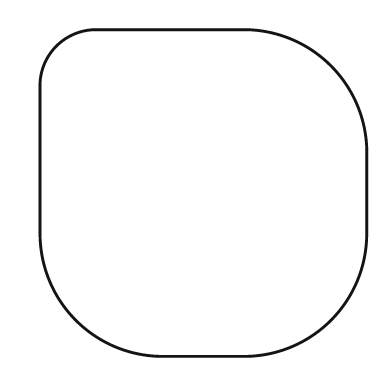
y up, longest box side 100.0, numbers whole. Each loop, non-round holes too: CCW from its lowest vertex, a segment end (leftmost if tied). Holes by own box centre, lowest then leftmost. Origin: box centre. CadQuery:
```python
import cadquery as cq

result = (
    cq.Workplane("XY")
    .moveTo(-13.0, -50.0)
    .lineTo(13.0, -50.0)
    .threePointArc((39.0, -39.0), (50.0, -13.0))
    .lineTo(50.0, 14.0)
    .threePointArc((39.0, 39.0), (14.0, 50.0))
    .lineTo(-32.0, 50.0)
    .threePointArc((-45.0, 45.0), (-50.0, 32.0))
    .lineTo(-50.0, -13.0)
    .threePointArc((-39.0, -39.0), (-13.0, -50.0))
    .close()
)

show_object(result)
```